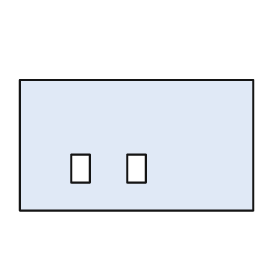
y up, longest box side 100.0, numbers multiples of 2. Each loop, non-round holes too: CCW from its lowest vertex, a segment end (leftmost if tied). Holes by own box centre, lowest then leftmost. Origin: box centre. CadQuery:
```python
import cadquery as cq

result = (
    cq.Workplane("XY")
    .moveTo(-50.0, -28.0)
    .lineTo(50.0, -28.0)
    .lineTo(50.0, 28.0)
    .lineTo(-50.0, 28.0)
    .close()
    .moveTo(-28.0, -16.0)
    .lineTo(-20.0, -16.0)
    .lineTo(-20.0, -4.0)
    .lineTo(-28.0, -4.0)
    .close()
    .moveTo(-4.0, -16.0)
    .lineTo(4.0, -16.0)
    .lineTo(4.0, -4.0)
    .lineTo(-4.0, -4.0)
    .close()
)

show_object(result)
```